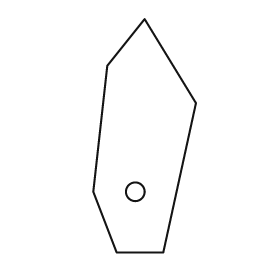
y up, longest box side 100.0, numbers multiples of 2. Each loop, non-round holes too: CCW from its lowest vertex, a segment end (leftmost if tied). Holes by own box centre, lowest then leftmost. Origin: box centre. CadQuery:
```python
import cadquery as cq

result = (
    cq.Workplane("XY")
    .moveTo(-12.0, -50.0)
    .lineTo(8.0, -50.0)
    .lineTo(22.0, 14.0)
    .lineTo(0.0, 50.0)
    .lineTo(-16.0, 30.0)
    .lineTo(-22.0, -24.0)
    .close()
    .moveTo(-4.0, -24.0)
    .circle(4.0)
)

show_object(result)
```